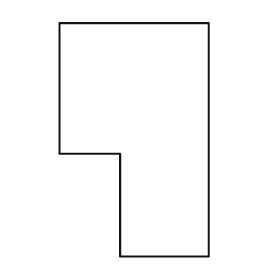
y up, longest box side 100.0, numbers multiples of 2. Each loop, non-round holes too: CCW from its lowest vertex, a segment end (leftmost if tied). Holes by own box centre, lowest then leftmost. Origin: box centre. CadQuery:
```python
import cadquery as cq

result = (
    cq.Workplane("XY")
    .moveTo(-6.0, -50.0)
    .lineTo(32.0, -50.0)
    .lineTo(32.0, 50.0)
    .lineTo(-32.0, 50.0)
    .lineTo(-32.0, -6.0)
    .lineTo(-6.0, -6.0)
    .close()
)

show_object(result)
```